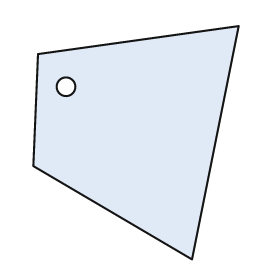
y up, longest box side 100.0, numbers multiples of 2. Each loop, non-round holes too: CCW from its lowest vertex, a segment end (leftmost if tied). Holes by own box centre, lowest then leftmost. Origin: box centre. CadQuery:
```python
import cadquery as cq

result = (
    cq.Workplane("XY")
    .moveTo(24.0, -50.0)
    .lineTo(44.0, 50.0)
    .lineTo(-42.0, 38.0)
    .lineTo(-44.0, -10.0)
    .close()
    .moveTo(-30.0, 24.0)
    .circle(4.0)
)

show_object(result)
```